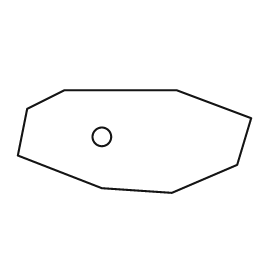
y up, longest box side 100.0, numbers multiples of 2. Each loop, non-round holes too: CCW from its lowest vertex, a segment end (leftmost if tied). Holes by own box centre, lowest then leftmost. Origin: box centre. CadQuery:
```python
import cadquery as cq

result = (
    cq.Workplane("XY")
    .moveTo(16.0, -22.0)
    .lineTo(44.0, -10.0)
    .lineTo(50.0, 10.0)
    .lineTo(18.0, 22.0)
    .lineTo(-30.0, 22.0)
    .lineTo(-46.0, 14.0)
    .lineTo(-50.0, -6.0)
    .lineTo(-14.0, -20.0)
    .close()
    .moveTo(-14.0, 2.0)
    .circle(4.0)
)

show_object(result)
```